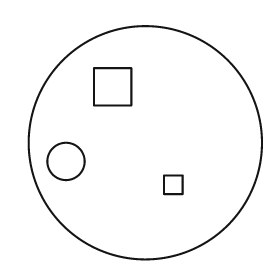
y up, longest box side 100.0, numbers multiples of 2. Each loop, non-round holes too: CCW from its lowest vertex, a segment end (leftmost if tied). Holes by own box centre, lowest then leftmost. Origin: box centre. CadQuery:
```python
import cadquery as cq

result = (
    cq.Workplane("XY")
    .moveTo(0.0, 0.0)
    .circle(50.0)
    .moveTo(8.0, -22.0)
    .lineTo(16.0, -22.0)
    .lineTo(16.0, -14.0)
    .lineTo(8.0, -14.0)
    .close()
    .moveTo(-34.0, -8.0)
    .circle(8.0)
    .moveTo(-22.0, 16.0)
    .lineTo(-6.0, 16.0)
    .lineTo(-6.0, 32.0)
    .lineTo(-22.0, 32.0)
    .close()
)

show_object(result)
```